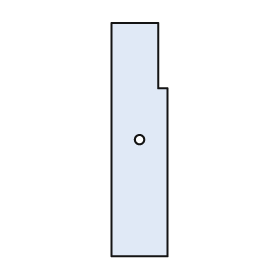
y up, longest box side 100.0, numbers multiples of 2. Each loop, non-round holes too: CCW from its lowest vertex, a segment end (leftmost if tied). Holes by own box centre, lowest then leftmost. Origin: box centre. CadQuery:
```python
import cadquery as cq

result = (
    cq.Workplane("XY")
    .moveTo(-12.0, -50.0)
    .lineTo(12.0, -50.0)
    .lineTo(12.0, 22.0)
    .lineTo(8.0, 22.0)
    .lineTo(8.0, 50.0)
    .lineTo(-12.0, 50.0)
    .close()
    .moveTo(0.0, 0.0)
    .circle(2.0)
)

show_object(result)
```